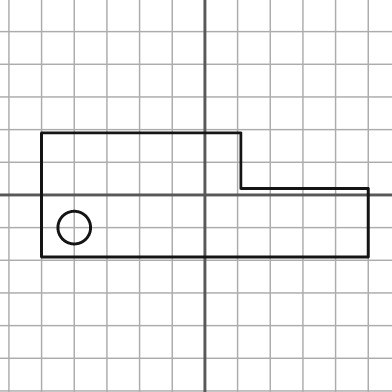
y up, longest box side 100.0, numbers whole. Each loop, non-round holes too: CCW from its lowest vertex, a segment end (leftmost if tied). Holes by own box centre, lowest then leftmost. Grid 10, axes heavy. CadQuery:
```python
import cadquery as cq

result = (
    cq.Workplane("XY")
    .moveTo(-50.0, -19.0)
    .lineTo(50.0, -19.0)
    .lineTo(50.0, 2.0)
    .lineTo(11.0, 2.0)
    .lineTo(11.0, 19.0)
    .lineTo(-50.0, 19.0)
    .close()
    .moveTo(-40.0, -10.0)
    .circle(5.0)
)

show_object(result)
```